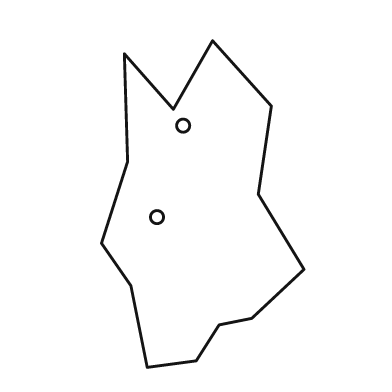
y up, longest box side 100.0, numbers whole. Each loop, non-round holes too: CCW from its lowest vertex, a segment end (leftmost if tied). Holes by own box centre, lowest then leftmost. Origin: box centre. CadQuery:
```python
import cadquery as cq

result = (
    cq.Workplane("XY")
    .moveTo(-17.0, -50.0)
    .lineTo(-2.0, -48.0)
    .lineTo(5.0, -37.0)
    .lineTo(15.0, -35.0)
    .lineTo(31.0, -20.0)
    .lineTo(17.0, 3.0)
    .lineTo(21.0, 30.0)
    .lineTo(3.0, 50.0)
    .lineTo(-9.0, 29.0)
    .lineTo(-24.0, 46.0)
    .lineTo(-23.0, 13.0)
    .lineTo(-31.0, -12.0)
    .lineTo(-22.0, -25.0)
    .close()
    .moveTo(-14.0, -4.0)
    .circle(2.0)
    .moveTo(-6.0, 24.0)
    .circle(2.0)
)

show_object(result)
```